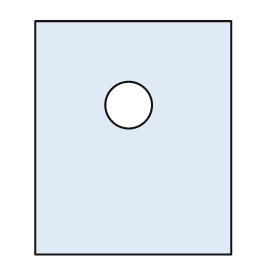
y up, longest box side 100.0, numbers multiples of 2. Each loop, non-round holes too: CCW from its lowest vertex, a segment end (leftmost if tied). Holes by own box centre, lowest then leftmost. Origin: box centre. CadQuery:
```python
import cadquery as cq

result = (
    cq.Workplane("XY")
    .moveTo(-42.0, -50.0)
    .lineTo(42.0, -50.0)
    .lineTo(42.0, 50.0)
    .lineTo(-42.0, 50.0)
    .close()
    .moveTo(-2.0, 14.0)
    .circle(10.0)
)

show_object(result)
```